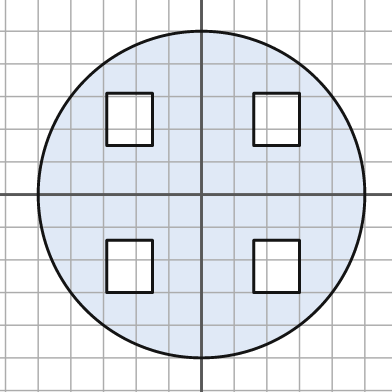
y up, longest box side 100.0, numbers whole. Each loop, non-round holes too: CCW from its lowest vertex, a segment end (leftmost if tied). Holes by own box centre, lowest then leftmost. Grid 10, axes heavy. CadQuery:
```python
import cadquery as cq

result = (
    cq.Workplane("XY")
    .moveTo(0.0, 0.0)
    .circle(50.0)
    .moveTo(-29.0, -30.0)
    .lineTo(-15.0, -30.0)
    .lineTo(-15.0, -14.0)
    .lineTo(-29.0, -14.0)
    .close()
    .moveTo(16.0, -30.0)
    .lineTo(30.0, -30.0)
    .lineTo(30.0, -14.0)
    .lineTo(16.0, -14.0)
    .close()
    .moveTo(-29.0, 15.0)
    .lineTo(-15.0, 15.0)
    .lineTo(-15.0, 31.0)
    .lineTo(-29.0, 31.0)
    .close()
    .moveTo(16.0, 15.0)
    .lineTo(30.0, 15.0)
    .lineTo(30.0, 31.0)
    .lineTo(16.0, 31.0)
    .close()
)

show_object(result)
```